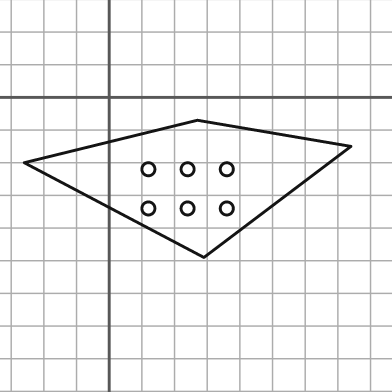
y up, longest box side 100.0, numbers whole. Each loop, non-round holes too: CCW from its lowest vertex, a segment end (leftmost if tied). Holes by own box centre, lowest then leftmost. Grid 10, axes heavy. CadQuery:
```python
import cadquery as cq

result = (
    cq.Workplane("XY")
    .moveTo(29.0, -49.0)
    .lineTo(74.0, -15.0)
    .lineTo(27.0, -7.0)
    .lineTo(-26.0, -20.0)
    .close()
    .moveTo(12.0, -34.0)
    .circle(2.0)
    .moveTo(24.0, -34.0)
    .circle(2.0)
    .moveTo(36.0, -34.0)
    .circle(2.0)
    .moveTo(12.0, -22.0)
    .circle(2.0)
    .moveTo(24.0, -22.0)
    .circle(2.0)
    .moveTo(36.0, -22.0)
    .circle(2.0)
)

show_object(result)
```